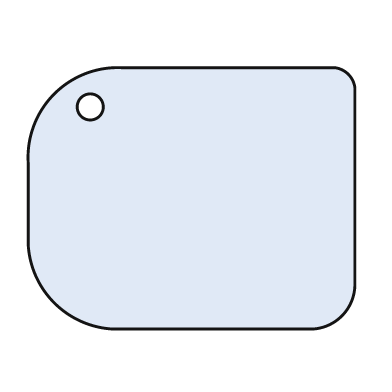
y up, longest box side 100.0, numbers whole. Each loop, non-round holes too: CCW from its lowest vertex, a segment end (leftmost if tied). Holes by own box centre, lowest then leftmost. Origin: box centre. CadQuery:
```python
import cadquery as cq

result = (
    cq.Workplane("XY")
    .moveTo(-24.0, -40.0)
    .lineTo(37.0, -40.0)
    .threePointArc((46.0, -36.0), (50.0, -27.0))
    .lineTo(50.0, 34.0)
    .threePointArc((48.0, 38.0), (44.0, 40.0))
    .lineTo(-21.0, 40.0)
    .threePointArc((-42.0, 32.0), (-50.0, 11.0))
    .lineTo(-50.0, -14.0)
    .threePointArc((-42.0, -32.0), (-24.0, -40.0))
    .close()
    .moveTo(-31.0, 28.0)
    .circle(4.0)
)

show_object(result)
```